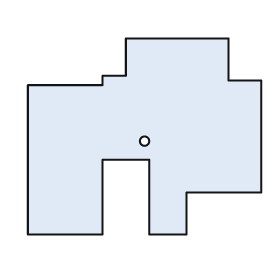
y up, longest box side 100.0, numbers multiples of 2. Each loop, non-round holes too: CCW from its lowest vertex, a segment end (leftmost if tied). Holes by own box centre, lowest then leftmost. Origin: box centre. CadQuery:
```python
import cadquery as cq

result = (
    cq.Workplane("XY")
    .moveTo(-50.0, -42.0)
    .lineTo(-18.0, -42.0)
    .lineTo(-18.0, -10.0)
    .lineTo(2.0, -10.0)
    .lineTo(2.0, -42.0)
    .lineTo(18.0, -42.0)
    .lineTo(18.0, -24.0)
    .lineTo(50.0, -24.0)
    .lineTo(50.0, 24.0)
    .lineTo(36.0, 24.0)
    .lineTo(36.0, 42.0)
    .lineTo(-8.0, 42.0)
    .lineTo(-8.0, 26.0)
    .lineTo(-18.0, 26.0)
    .lineTo(-18.0, 22.0)
    .lineTo(-50.0, 22.0)
    .close()
    .moveTo(0.0, -2.0)
    .circle(2.0)
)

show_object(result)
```